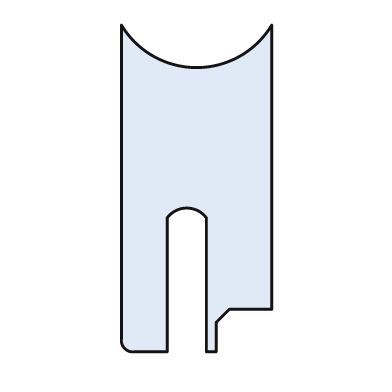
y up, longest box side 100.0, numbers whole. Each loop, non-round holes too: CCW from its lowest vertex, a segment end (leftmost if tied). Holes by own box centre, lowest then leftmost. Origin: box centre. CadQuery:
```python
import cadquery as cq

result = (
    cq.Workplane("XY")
    .moveTo(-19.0, -50.0)
    .lineTo(-9.0, -50.0)
    .lineTo(-9.0, -9.0)
    .threePointArc((-3.0, -6.0), (3.0, -9.0))
    .lineTo(3.0, -50.0)
    .lineTo(6.0, -50.0)
    .lineTo(6.0, -41.0)
    .lineTo(10.0, -37.0)
    .lineTo(23.0, -37.0)
    .lineTo(23.0, 50.0)
    .threePointArc((0.0, 37.0), (-23.0, 50.0))
    .lineTo(-23.0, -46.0)
    .threePointArc((-22.0, -49.0), (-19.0, -50.0))
    .close()
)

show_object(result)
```